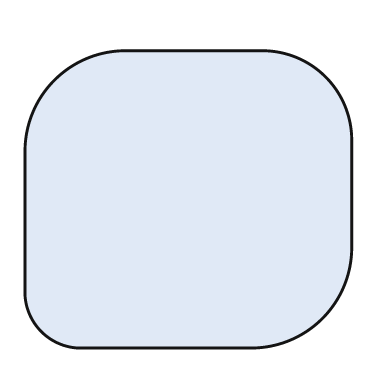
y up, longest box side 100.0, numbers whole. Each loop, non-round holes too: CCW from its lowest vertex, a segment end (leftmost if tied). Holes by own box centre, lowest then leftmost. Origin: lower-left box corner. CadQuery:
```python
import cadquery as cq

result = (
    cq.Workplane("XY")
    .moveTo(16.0, 0.0)
    .lineTo(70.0, 0.0)
    .threePointArc((91.0, 9.0), (100.0, 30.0))
    .lineTo(100.0, 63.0)
    .threePointArc((92.0, 83.0), (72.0, 91.0))
    .lineTo(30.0, 91.0)
    .threePointArc((9.0, 82.0), (0.0, 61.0))
    .lineTo(0.0, 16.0)
    .threePointArc((5.0, 5.0), (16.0, 0.0))
    .close()
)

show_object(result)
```